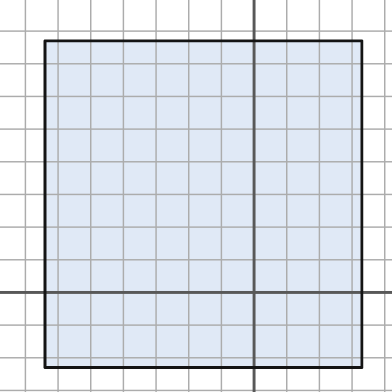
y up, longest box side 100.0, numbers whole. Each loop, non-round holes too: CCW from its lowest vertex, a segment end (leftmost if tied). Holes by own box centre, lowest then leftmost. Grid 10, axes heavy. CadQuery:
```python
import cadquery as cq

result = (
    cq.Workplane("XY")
    .moveTo(-64.0, -23.0)
    .lineTo(33.0, -23.0)
    .lineTo(33.0, 77.0)
    .lineTo(-64.0, 77.0)
    .close()
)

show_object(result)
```